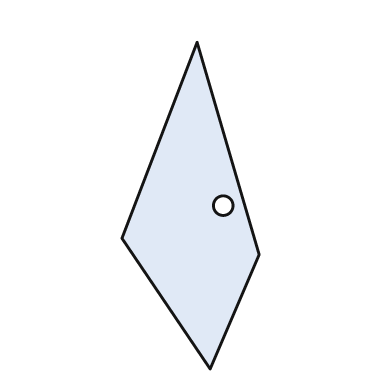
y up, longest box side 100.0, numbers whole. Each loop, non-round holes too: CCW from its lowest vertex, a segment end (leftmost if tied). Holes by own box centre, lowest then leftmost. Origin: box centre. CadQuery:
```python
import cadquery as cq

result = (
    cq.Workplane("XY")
    .moveTo(6.0, -50.0)
    .lineTo(21.0, -15.0)
    .lineTo(2.0, 50.0)
    .lineTo(-21.0, -10.0)
    .close()
    .moveTo(10.0, 0.0)
    .circle(3.0)
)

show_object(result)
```